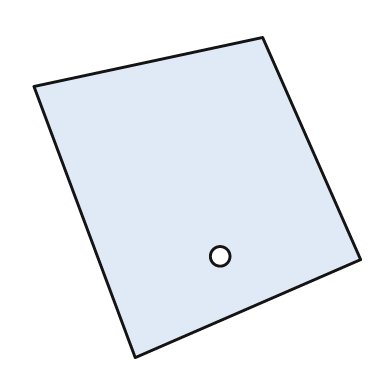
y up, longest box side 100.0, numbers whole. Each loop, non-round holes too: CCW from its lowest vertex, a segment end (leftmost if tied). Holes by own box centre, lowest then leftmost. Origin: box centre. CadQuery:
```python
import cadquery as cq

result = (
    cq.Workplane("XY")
    .moveTo(-19.0, -49.0)
    .lineTo(50.0, -19.0)
    .lineTo(20.0, 49.0)
    .lineTo(-50.0, 34.0)
    .close()
    .moveTo(7.0, -18.0)
    .circle(3.0)
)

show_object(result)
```